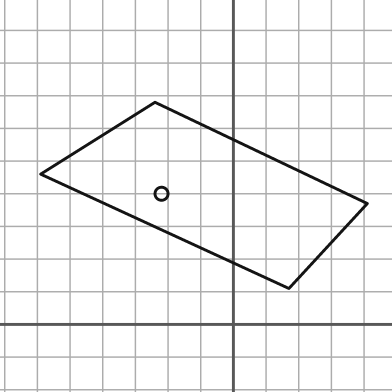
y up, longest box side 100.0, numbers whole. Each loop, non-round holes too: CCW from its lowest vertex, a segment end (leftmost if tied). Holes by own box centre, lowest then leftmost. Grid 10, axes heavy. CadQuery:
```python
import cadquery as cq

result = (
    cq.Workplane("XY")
    .moveTo(17.0, 11.0)
    .lineTo(41.0, 37.0)
    .lineTo(-24.0, 68.0)
    .lineTo(-59.0, 46.0)
    .close()
    .moveTo(-22.0, 40.0)
    .circle(2.0)
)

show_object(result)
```